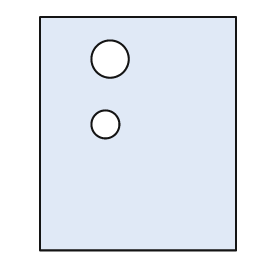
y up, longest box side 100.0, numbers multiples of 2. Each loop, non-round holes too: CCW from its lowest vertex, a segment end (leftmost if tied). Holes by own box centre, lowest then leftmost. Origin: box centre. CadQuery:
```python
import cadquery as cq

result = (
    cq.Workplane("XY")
    .moveTo(-42.0, -50.0)
    .lineTo(42.0, -50.0)
    .lineTo(42.0, 50.0)
    .lineTo(-42.0, 50.0)
    .close()
    .moveTo(-14.0, 4.0)
    .circle(6.0)
    .moveTo(-12.0, 32.0)
    .circle(8.0)
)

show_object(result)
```